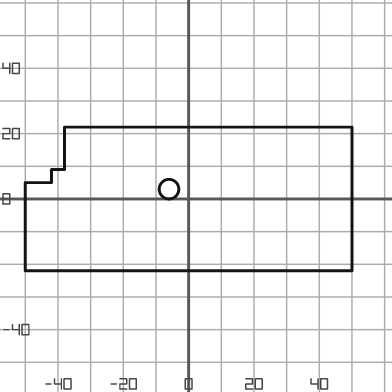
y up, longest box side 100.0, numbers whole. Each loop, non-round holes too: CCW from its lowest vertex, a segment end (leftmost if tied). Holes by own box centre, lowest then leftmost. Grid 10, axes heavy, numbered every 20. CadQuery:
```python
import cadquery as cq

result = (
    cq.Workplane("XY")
    .moveTo(-50.0, -22.0)
    .lineTo(50.0, -22.0)
    .lineTo(50.0, 22.0)
    .lineTo(-38.0, 22.0)
    .lineTo(-38.0, 9.0)
    .lineTo(-42.0, 9.0)
    .lineTo(-42.0, 5.0)
    .lineTo(-50.0, 5.0)
    .close()
    .moveTo(-6.0, 3.0)
    .circle(3.0)
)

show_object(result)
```